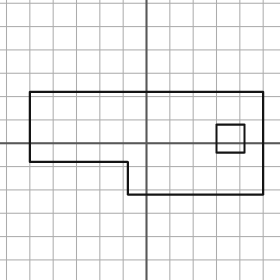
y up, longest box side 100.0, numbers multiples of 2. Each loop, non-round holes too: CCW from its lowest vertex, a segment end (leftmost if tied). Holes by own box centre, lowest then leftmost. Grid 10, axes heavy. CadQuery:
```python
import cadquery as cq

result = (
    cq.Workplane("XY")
    .moveTo(-8.0, -22.0)
    .lineTo(50.0, -22.0)
    .lineTo(50.0, 22.0)
    .lineTo(-50.0, 22.0)
    .lineTo(-50.0, -8.0)
    .lineTo(-8.0, -8.0)
    .close()
    .moveTo(30.0, -4.0)
    .lineTo(42.0, -4.0)
    .lineTo(42.0, 8.0)
    .lineTo(30.0, 8.0)
    .close()
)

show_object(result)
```